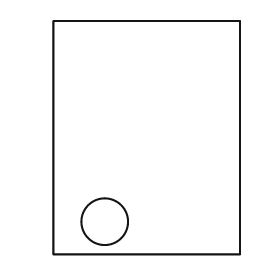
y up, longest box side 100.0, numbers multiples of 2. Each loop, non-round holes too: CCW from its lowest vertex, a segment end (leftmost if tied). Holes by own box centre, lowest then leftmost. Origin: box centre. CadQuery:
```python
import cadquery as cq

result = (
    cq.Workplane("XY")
    .moveTo(-40.0, -50.0)
    .lineTo(40.0, -50.0)
    .lineTo(40.0, 50.0)
    .lineTo(-40.0, 50.0)
    .close()
    .moveTo(-18.0, -36.0)
    .circle(10.0)
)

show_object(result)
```